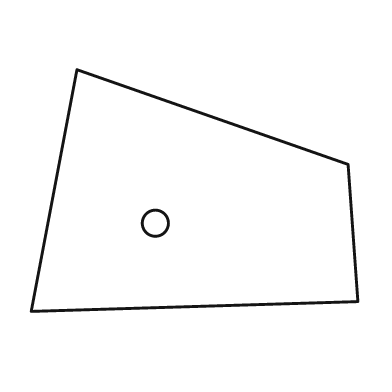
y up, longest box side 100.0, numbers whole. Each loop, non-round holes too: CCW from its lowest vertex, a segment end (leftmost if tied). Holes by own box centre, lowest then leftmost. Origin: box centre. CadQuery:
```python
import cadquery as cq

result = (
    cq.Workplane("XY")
    .moveTo(-50.0, -37.0)
    .lineTo(50.0, -34.0)
    .lineTo(47.0, 8.0)
    .lineTo(-36.0, 37.0)
    .close()
    .moveTo(-12.0, -10.0)
    .circle(4.0)
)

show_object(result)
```